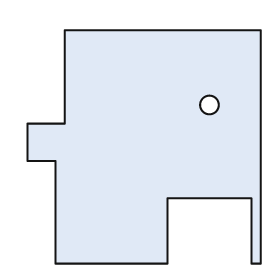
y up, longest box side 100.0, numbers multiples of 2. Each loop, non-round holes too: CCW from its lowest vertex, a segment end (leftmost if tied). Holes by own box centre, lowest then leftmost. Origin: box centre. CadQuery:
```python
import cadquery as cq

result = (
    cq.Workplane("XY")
    .moveTo(-38.0, -50.0)
    .lineTo(10.0, -50.0)
    .lineTo(10.0, -22.0)
    .lineTo(46.0, -22.0)
    .lineTo(46.0, -50.0)
    .lineTo(50.0, -50.0)
    .lineTo(50.0, 50.0)
    .lineTo(-34.0, 50.0)
    .lineTo(-34.0, 10.0)
    .lineTo(-50.0, 10.0)
    .lineTo(-50.0, -6.0)
    .lineTo(-38.0, -6.0)
    .close()
    .moveTo(28.0, 18.0)
    .circle(4.0)
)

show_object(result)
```